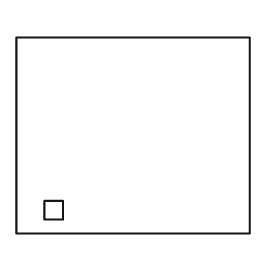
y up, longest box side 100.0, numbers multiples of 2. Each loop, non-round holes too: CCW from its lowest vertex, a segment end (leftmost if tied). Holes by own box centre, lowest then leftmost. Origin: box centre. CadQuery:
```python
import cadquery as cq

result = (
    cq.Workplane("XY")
    .moveTo(-50.0, -42.0)
    .lineTo(50.0, -42.0)
    .lineTo(50.0, 42.0)
    .lineTo(-50.0, 42.0)
    .close()
    .moveTo(-38.0, -36.0)
    .lineTo(-30.0, -36.0)
    .lineTo(-30.0, -28.0)
    .lineTo(-38.0, -28.0)
    .close()
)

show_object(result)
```